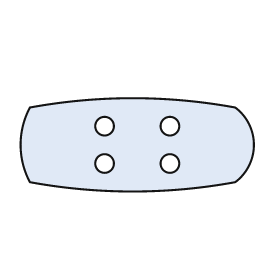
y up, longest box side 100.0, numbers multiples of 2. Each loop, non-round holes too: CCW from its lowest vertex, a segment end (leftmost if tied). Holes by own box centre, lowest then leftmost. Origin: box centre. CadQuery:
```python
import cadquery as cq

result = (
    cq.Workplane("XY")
    .moveTo(-46.0, -16.0)
    .threePointArc((-2.0, -20.0), (42.0, -16.0))
    .threePointArc((50.0, 0.0), (42.0, 16.0))
    .threePointArc((-2.0, 20.0), (-46.0, 16.0))
    .threePointArc((-50.0, 0.0), (-46.0, -16.0))
    .close()
    .moveTo(-14.0, -8.0)
    .circle(4.0)
    .moveTo(14.0, -8.0)
    .circle(4.0)
    .moveTo(-14.0, 8.0)
    .circle(4.0)
    .moveTo(14.0, 8.0)
    .circle(4.0)
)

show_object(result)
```